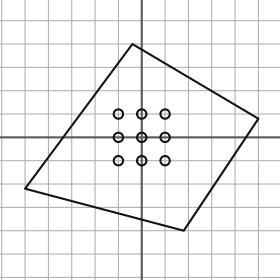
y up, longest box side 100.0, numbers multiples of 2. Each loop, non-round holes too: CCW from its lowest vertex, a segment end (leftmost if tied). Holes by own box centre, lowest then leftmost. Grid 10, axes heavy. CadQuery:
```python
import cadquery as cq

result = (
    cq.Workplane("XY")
    .moveTo(18.0, -40.0)
    .lineTo(50.0, 8.0)
    .lineTo(-4.0, 40.0)
    .lineTo(-50.0, -22.0)
    .close()
    .moveTo(-10.0, -10.0)
    .circle(2.0)
    .moveTo(0.0, -10.0)
    .circle(2.0)
    .moveTo(10.0, -10.0)
    .circle(2.0)
    .moveTo(-10.0, 0.0)
    .circle(2.0)
    .moveTo(0.0, 0.0)
    .circle(2.0)
    .moveTo(10.0, 0.0)
    .circle(2.0)
    .moveTo(-10.0, 10.0)
    .circle(2.0)
    .moveTo(0.0, 10.0)
    .circle(2.0)
    .moveTo(10.0, 10.0)
    .circle(2.0)
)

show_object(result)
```